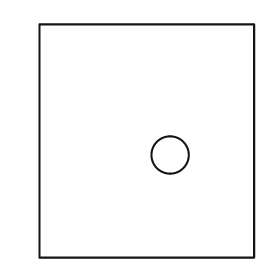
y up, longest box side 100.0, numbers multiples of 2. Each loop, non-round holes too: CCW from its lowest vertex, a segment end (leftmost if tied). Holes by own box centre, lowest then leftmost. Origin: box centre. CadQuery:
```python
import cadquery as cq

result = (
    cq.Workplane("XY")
    .moveTo(-46.0, -50.0)
    .lineTo(46.0, -50.0)
    .lineTo(46.0, 50.0)
    .lineTo(-46.0, 50.0)
    .close()
    .moveTo(10.0, -6.0)
    .circle(8.0)
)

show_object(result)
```